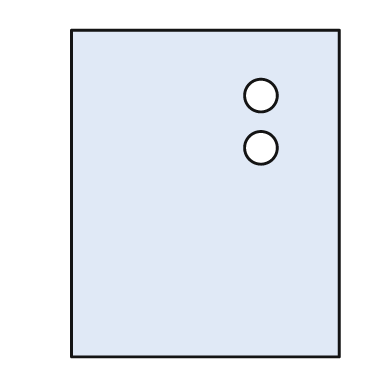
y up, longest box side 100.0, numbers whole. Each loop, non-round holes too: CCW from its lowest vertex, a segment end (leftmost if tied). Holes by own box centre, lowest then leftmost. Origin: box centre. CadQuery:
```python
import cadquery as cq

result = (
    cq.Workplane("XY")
    .moveTo(-41.0, -50.0)
    .lineTo(41.0, -50.0)
    .lineTo(41.0, 50.0)
    .lineTo(-41.0, 50.0)
    .close()
    .moveTo(17.0, 14.0)
    .circle(5.0)
    .moveTo(17.0, 30.0)
    .circle(5.0)
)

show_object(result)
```